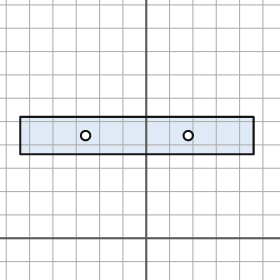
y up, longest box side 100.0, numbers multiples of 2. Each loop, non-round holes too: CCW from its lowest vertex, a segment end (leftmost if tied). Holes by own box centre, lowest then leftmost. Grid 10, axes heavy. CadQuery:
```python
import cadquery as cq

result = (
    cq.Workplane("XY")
    .moveTo(-54.0, 36.0)
    .lineTo(46.0, 36.0)
    .lineTo(46.0, 52.0)
    .lineTo(-54.0, 52.0)
    .close()
    .moveTo(-26.0, 44.0)
    .circle(2.0)
    .moveTo(18.0, 44.0)
    .circle(2.0)
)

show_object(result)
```